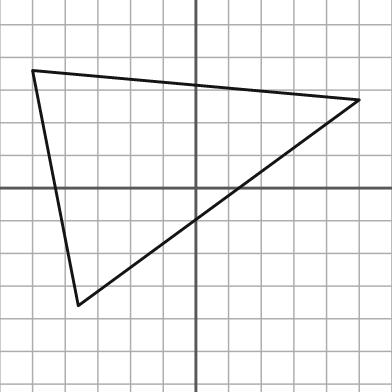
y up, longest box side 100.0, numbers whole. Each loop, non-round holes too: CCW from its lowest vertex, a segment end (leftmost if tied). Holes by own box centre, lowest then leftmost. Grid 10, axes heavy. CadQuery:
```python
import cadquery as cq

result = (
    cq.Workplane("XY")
    .moveTo(-36.0, -36.0)
    .lineTo(50.0, 27.0)
    .lineTo(-50.0, 36.0)
    .close()
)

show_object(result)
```